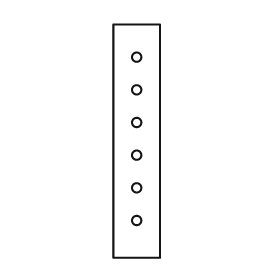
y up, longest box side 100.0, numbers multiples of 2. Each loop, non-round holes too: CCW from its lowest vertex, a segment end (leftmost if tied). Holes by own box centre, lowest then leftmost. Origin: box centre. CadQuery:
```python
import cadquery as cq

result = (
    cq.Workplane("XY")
    .moveTo(-10.0, -50.0)
    .lineTo(10.0, -50.0)
    .lineTo(10.0, 50.0)
    .lineTo(-10.0, 50.0)
    .close()
    .moveTo(0.0, -34.0)
    .circle(2.0)
    .moveTo(0.0, -20.0)
    .circle(2.0)
    .moveTo(0.0, -6.0)
    .circle(2.0)
    .moveTo(0.0, 8.0)
    .circle(2.0)
    .moveTo(0.0, 22.0)
    .circle(2.0)
    .moveTo(0.0, 36.0)
    .circle(2.0)
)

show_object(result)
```